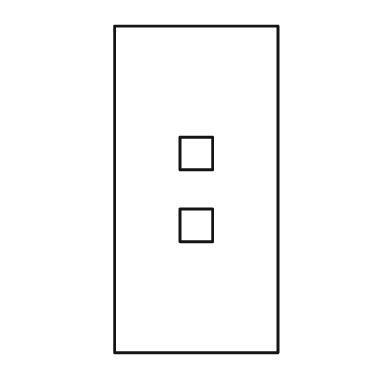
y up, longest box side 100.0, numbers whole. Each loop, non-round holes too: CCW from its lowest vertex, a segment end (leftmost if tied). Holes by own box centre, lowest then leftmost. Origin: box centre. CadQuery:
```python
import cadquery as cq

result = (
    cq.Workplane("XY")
    .moveTo(-25.0, -50.0)
    .lineTo(25.0, -50.0)
    .lineTo(25.0, 50.0)
    .lineTo(-25.0, 50.0)
    .close()
    .moveTo(-5.0, -16.0)
    .lineTo(5.0, -16.0)
    .lineTo(5.0, -6.0)
    .lineTo(-5.0, -6.0)
    .close()
    .moveTo(-5.0, 6.0)
    .lineTo(5.0, 6.0)
    .lineTo(5.0, 16.0)
    .lineTo(-5.0, 16.0)
    .close()
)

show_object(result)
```